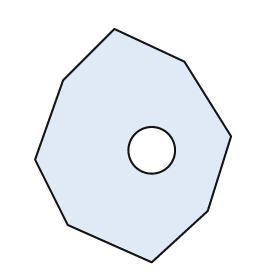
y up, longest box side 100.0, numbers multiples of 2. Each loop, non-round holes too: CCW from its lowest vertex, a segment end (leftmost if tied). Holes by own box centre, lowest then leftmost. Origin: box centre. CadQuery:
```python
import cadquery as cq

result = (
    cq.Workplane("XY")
    .moveTo(8.0, -50.0)
    .lineTo(32.0, -28.0)
    .lineTo(42.0, 4.0)
    .lineTo(22.0, 36.0)
    .lineTo(-8.0, 50.0)
    .lineTo(-30.0, 28.0)
    .lineTo(-42.0, -6.0)
    .lineTo(-28.0, -34.0)
    .close()
    .moveTo(8.0, -2.0)
    .circle(10.0)
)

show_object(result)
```